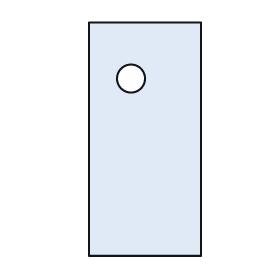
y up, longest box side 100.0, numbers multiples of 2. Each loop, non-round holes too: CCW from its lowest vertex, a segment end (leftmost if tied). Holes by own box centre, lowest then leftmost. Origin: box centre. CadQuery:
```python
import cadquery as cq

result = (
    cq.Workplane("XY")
    .moveTo(-24.0, -50.0)
    .lineTo(24.0, -50.0)
    .lineTo(24.0, 50.0)
    .lineTo(-24.0, 50.0)
    .close()
    .moveTo(-6.0, 26.0)
    .circle(6.0)
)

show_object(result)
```